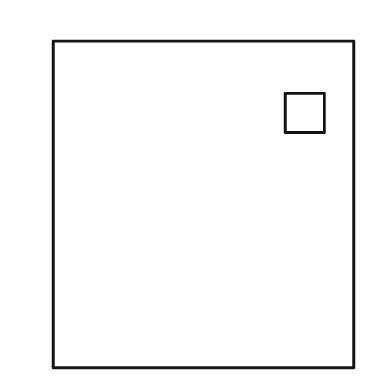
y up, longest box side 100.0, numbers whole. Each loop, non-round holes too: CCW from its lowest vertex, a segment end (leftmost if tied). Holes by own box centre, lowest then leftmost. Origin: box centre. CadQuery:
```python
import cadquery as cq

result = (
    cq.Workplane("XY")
    .moveTo(-46.0, -50.0)
    .lineTo(46.0, -50.0)
    .lineTo(46.0, 50.0)
    .lineTo(-46.0, 50.0)
    .close()
    .moveTo(25.0, 22.0)
    .lineTo(37.0, 22.0)
    .lineTo(37.0, 34.0)
    .lineTo(25.0, 34.0)
    .close()
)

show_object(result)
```